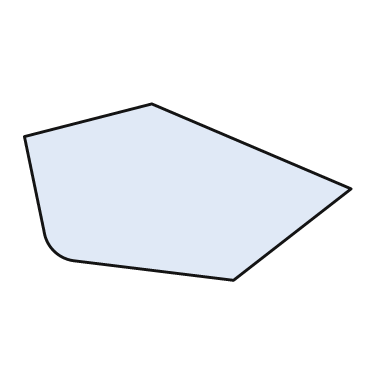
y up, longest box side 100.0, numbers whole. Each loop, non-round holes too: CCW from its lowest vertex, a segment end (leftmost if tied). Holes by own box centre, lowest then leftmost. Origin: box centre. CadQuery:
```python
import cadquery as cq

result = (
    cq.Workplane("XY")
    .moveTo(14.0, -27.0)
    .lineTo(50.0, 1.0)
    .lineTo(-11.0, 27.0)
    .lineTo(-50.0, 17.0)
    .lineTo(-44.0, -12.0)
    .threePointArc((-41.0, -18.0), (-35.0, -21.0))
    .close()
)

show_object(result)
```